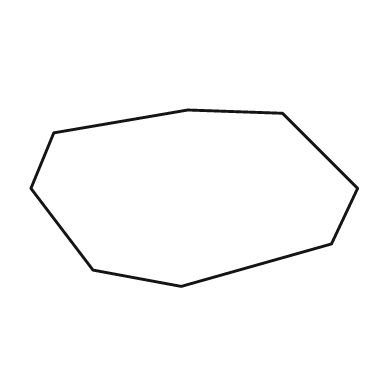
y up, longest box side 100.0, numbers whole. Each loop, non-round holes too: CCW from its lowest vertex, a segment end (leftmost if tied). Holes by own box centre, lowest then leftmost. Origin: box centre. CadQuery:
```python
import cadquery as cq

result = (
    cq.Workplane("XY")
    .moveTo(-4.0, -27.0)
    .lineTo(42.0, -14.0)
    .lineTo(50.0, 3.0)
    .lineTo(27.0, 26.0)
    .lineTo(-2.0, 27.0)
    .lineTo(-43.0, 20.0)
    .lineTo(-50.0, 3.0)
    .lineTo(-31.0, -22.0)
    .close()
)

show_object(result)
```